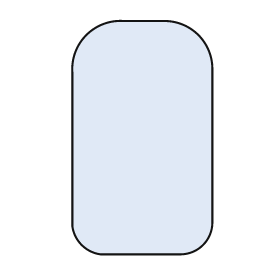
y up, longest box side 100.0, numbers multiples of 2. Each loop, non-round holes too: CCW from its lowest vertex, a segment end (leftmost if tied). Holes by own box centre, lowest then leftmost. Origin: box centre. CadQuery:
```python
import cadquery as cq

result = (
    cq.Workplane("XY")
    .moveTo(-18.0, -50.0)
    .lineTo(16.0, -50.0)
    .threePointArc((26.0, -46.0), (30.0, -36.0))
    .lineTo(30.0, 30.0)
    .threePointArc((24.0, 44.0), (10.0, 50.0))
    .lineTo(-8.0, 50.0)
    .threePointArc((-24.0, 44.0), (-30.0, 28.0))
    .lineTo(-30.0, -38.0)
    .threePointArc((-26.0, -46.0), (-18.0, -50.0))
    .close()
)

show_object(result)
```